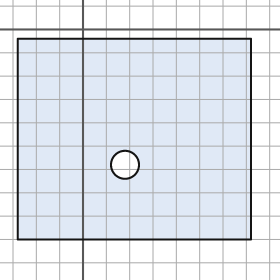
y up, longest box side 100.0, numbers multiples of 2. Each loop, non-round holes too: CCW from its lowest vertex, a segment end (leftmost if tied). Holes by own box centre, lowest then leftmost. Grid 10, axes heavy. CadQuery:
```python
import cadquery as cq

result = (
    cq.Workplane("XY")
    .moveTo(-28.0, -90.0)
    .lineTo(72.0, -90.0)
    .lineTo(72.0, -4.0)
    .lineTo(-28.0, -4.0)
    .close()
    .moveTo(18.0, -58.0)
    .circle(6.0)
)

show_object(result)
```